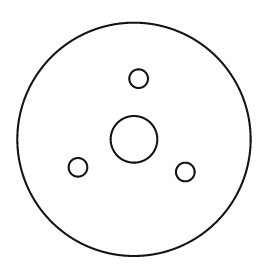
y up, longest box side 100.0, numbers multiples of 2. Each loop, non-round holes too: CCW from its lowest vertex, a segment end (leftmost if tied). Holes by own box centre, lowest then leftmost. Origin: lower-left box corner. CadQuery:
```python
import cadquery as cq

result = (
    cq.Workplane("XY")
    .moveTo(50.0, 50.0)
    .circle(50.0)
    .moveTo(72.0, 36.0)
    .circle(4.0)
    .moveTo(26.0, 38.0)
    .circle(4.0)
    .moveTo(50.0, 50.0)
    .circle(10.0)
    .moveTo(52.0, 76.0)
    .circle(4.0)
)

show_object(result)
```